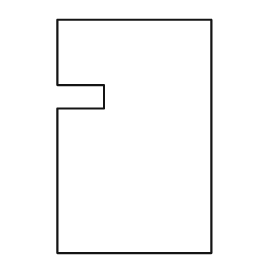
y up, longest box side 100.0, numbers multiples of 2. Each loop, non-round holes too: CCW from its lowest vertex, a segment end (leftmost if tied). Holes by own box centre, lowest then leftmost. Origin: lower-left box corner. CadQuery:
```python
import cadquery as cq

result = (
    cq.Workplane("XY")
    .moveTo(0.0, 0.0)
    .lineTo(66.0, 0.0)
    .lineTo(66.0, 100.0)
    .lineTo(0.0, 100.0)
    .lineTo(0.0, 72.0)
    .lineTo(20.0, 72.0)
    .lineTo(20.0, 62.0)
    .lineTo(0.0, 62.0)
    .close()
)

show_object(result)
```